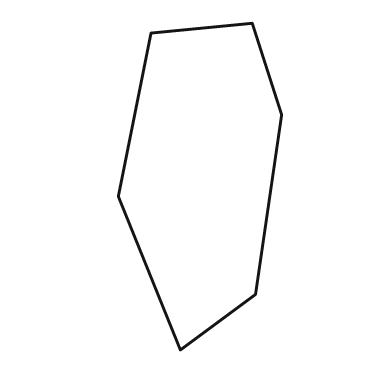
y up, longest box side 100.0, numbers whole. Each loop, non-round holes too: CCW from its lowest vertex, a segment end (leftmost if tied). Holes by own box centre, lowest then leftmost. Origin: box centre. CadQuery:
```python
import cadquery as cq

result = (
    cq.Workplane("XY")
    .moveTo(-6.0, -50.0)
    .lineTo(17.0, -33.0)
    .lineTo(25.0, 22.0)
    .lineTo(16.0, 50.0)
    .lineTo(-15.0, 47.0)
    .lineTo(-25.0, -3.0)
    .close()
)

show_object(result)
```